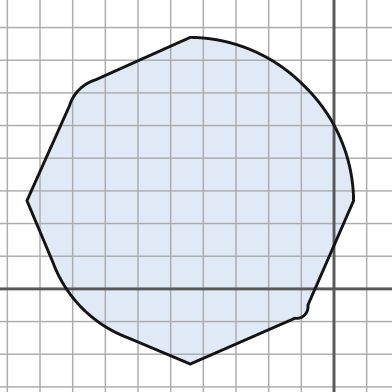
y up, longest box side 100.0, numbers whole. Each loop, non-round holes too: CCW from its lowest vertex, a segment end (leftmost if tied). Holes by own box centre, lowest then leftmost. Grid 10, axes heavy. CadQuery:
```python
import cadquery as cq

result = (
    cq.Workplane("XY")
    .moveTo(-44.0, -23.0)
    .lineTo(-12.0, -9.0)
    .threePointArc((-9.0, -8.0), (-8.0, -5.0))
    .lineTo(6.0, 27.0)
    .threePointArc((2.0, 46.0), (-9.0, 62.0))
    .threePointArc((-25.0, 73.0), (-44.0, 77.0))
    .lineTo(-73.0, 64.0)
    .threePointArc((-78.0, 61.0), (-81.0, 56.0))
    .lineTo(-94.0, 27.0)
    .lineTo(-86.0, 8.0)
    .threePointArc((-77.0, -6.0), (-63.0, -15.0))
    .close()
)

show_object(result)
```